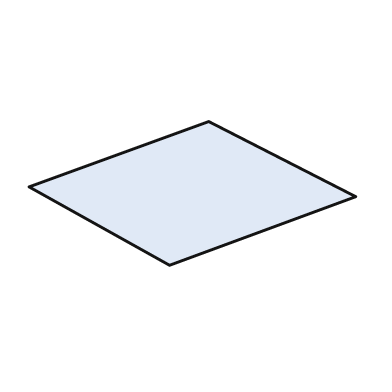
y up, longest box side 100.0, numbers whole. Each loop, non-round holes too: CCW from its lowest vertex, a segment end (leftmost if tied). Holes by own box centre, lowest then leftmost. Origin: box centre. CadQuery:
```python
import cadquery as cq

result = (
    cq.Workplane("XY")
    .moveTo(-7.0, -22.0)
    .lineTo(50.0, -1.0)
    .lineTo(5.0, 22.0)
    .lineTo(-50.0, 2.0)
    .close()
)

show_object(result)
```